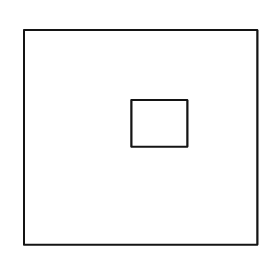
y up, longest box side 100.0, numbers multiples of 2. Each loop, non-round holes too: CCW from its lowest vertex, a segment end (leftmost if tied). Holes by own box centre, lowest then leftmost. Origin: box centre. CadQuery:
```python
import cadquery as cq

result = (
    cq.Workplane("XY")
    .moveTo(-50.0, -46.0)
    .lineTo(50.0, -46.0)
    .lineTo(50.0, 46.0)
    .lineTo(-50.0, 46.0)
    .close()
    .moveTo(-4.0, -4.0)
    .lineTo(20.0, -4.0)
    .lineTo(20.0, 16.0)
    .lineTo(-4.0, 16.0)
    .close()
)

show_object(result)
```